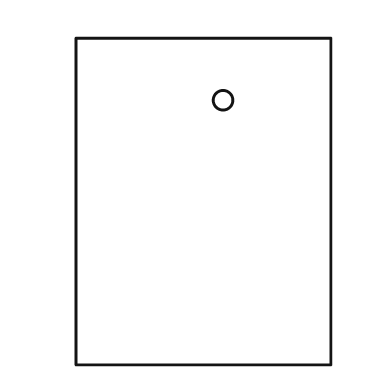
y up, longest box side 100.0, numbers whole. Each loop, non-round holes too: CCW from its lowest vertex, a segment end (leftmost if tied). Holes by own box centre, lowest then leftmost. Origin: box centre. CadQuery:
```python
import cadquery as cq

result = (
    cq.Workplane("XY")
    .moveTo(-39.0, -50.0)
    .lineTo(39.0, -50.0)
    .lineTo(39.0, 50.0)
    .lineTo(-39.0, 50.0)
    .close()
    .moveTo(6.0, 31.0)
    .circle(3.0)
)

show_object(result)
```